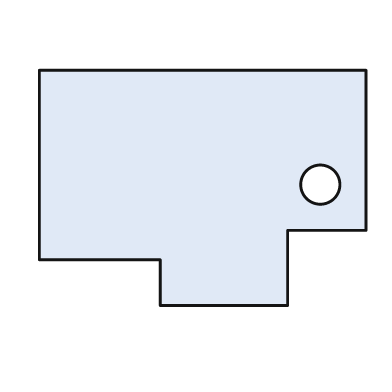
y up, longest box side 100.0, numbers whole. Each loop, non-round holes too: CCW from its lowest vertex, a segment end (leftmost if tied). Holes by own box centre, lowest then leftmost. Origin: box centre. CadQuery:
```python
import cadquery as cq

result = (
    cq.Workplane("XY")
    .moveTo(-13.0, -36.0)
    .lineTo(26.0, -36.0)
    .lineTo(26.0, -13.0)
    .lineTo(50.0, -13.0)
    .lineTo(50.0, 36.0)
    .lineTo(-50.0, 36.0)
    .lineTo(-50.0, -22.0)
    .lineTo(-13.0, -22.0)
    .close()
    .moveTo(36.0, 1.0)
    .circle(6.0)
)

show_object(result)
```